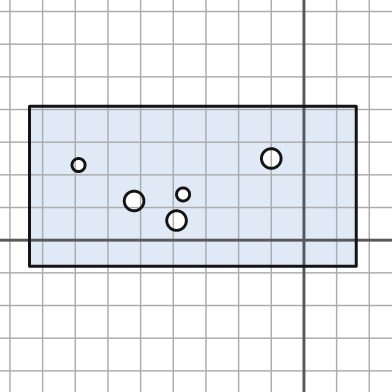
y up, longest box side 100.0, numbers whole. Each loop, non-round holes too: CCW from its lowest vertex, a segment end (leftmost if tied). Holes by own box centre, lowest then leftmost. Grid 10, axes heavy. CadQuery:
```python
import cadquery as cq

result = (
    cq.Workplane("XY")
    .moveTo(-84.0, -8.0)
    .lineTo(16.0, -8.0)
    .lineTo(16.0, 41.0)
    .lineTo(-84.0, 41.0)
    .close()
    .moveTo(-39.0, 6.0)
    .circle(3.0)
    .moveTo(-52.0, 12.0)
    .circle(3.0)
    .moveTo(-37.0, 14.0)
    .circle(2.0)
    .moveTo(-69.0, 23.0)
    .circle(2.0)
    .moveTo(-10.0, 25.0)
    .circle(3.0)
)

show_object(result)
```